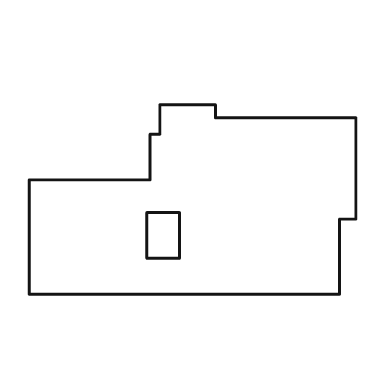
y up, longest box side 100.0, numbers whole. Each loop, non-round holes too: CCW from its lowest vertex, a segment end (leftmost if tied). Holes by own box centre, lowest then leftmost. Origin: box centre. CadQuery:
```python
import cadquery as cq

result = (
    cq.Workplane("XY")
    .moveTo(-50.0, -29.0)
    .lineTo(45.0, -29.0)
    .lineTo(45.0, -6.0)
    .lineTo(50.0, -6.0)
    .lineTo(50.0, 25.0)
    .lineTo(7.0, 25.0)
    .lineTo(7.0, 29.0)
    .lineTo(-10.0, 29.0)
    .lineTo(-10.0, 20.0)
    .lineTo(-13.0, 20.0)
    .lineTo(-13.0, 6.0)
    .lineTo(-50.0, 6.0)
    .close()
    .moveTo(-14.0, -18.0)
    .lineTo(-4.0, -18.0)
    .lineTo(-4.0, -4.0)
    .lineTo(-14.0, -4.0)
    .close()
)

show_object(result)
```